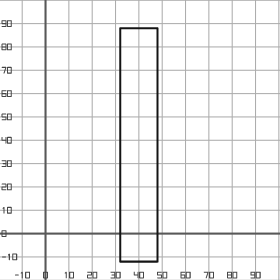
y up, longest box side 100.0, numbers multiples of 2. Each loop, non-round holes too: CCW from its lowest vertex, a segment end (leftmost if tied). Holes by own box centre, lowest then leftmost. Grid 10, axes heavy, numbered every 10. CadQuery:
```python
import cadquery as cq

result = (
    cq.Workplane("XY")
    .moveTo(32.0, -12.0)
    .lineTo(48.0, -12.0)
    .lineTo(48.0, 88.0)
    .lineTo(32.0, 88.0)
    .close()
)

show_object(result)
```